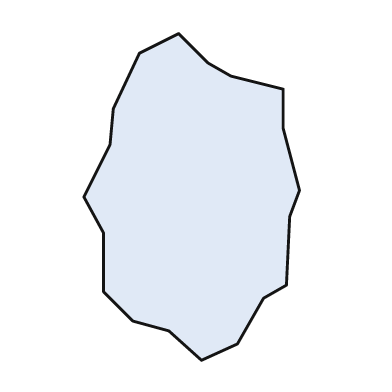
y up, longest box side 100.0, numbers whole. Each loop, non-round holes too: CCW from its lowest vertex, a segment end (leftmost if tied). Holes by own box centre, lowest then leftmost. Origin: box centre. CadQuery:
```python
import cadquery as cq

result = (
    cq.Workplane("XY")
    .moveTo(3.0, -50.0)
    .lineTo(14.0, -45.0)
    .lineTo(22.0, -31.0)
    .lineTo(29.0, -27.0)
    .lineTo(30.0, -6.0)
    .lineTo(33.0, 2.0)
    .lineTo(28.0, 21.0)
    .lineTo(28.0, 33.0)
    .lineTo(12.0, 37.0)
    .lineTo(5.0, 41.0)
    .lineTo(-4.0, 50.0)
    .lineTo(-16.0, 44.0)
    .lineTo(-24.0, 27.0)
    .lineTo(-25.0, 16.0)
    .lineTo(-33.0, 0.0)
    .lineTo(-27.0, -11.0)
    .lineTo(-27.0, -29.0)
    .lineTo(-18.0, -38.0)
    .lineTo(-7.0, -41.0)
    .close()
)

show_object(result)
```